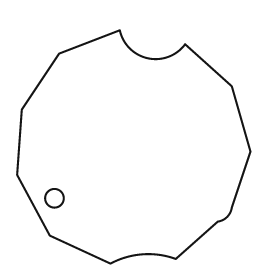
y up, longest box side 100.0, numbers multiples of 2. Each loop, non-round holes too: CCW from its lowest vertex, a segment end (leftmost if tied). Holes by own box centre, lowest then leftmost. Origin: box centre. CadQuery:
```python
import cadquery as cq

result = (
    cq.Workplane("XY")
    .moveTo(-10.0, -50.0)
    .threePointArc((4.0, -46.0), (18.0, -48.0))
    .lineTo(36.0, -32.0)
    .threePointArc((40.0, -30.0), (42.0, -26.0))
    .lineTo(50.0, -2.0)
    .lineTo(42.0, 26.0)
    .lineTo(22.0, 44.0)
    .threePointArc((6.0, 38.0), (-6.0, 50.0))
    .lineTo(-32.0, 40.0)
    .lineTo(-48.0, 16.0)
    .lineTo(-50.0, -12.0)
    .lineTo(-36.0, -38.0)
    .close()
    .moveTo(-34.0, -22.0)
    .circle(4.0)
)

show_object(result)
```